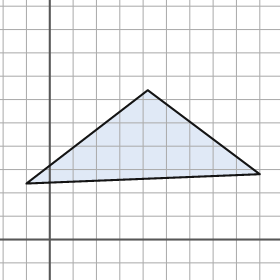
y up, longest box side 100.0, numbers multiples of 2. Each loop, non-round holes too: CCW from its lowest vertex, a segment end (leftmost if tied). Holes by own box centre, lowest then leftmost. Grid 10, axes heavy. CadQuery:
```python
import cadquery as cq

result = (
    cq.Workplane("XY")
    .moveTo(-10.0, 24.0)
    .lineTo(90.0, 28.0)
    .lineTo(42.0, 64.0)
    .close()
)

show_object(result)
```